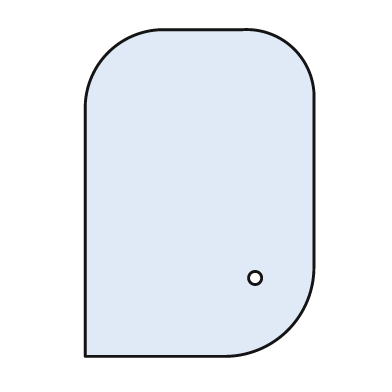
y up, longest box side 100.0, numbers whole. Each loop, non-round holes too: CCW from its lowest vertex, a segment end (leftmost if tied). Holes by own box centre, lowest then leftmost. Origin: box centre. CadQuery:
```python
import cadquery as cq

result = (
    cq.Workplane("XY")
    .moveTo(-35.0, -50.0)
    .lineTo(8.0, -50.0)
    .threePointArc((27.0, -42.0), (35.0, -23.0))
    .lineTo(35.0, 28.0)
    .threePointArc((29.0, 44.0), (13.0, 50.0))
    .lineTo(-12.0, 50.0)
    .threePointArc((-28.0, 43.0), (-35.0, 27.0))
    .close()
    .moveTo(17.0, -26.0)
    .circle(2.0)
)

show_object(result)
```